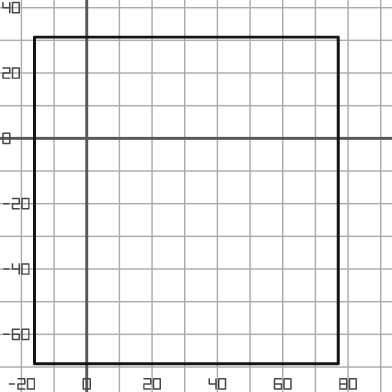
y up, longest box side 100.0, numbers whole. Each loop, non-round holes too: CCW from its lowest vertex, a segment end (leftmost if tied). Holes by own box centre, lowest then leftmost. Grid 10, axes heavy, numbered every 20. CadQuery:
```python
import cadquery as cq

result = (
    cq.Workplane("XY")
    .moveTo(-16.0, -69.0)
    .lineTo(77.0, -69.0)
    .lineTo(77.0, 31.0)
    .lineTo(-16.0, 31.0)
    .close()
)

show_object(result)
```